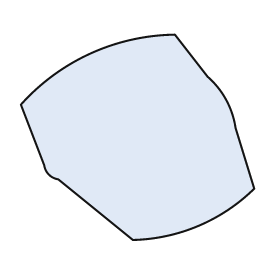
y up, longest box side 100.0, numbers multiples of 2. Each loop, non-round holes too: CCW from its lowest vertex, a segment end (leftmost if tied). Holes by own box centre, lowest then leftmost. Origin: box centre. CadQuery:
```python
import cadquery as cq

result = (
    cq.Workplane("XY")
    .moveTo(-2.0, -44.0)
    .threePointArc((26.0, -38.0), (50.0, -22.0))
    .lineTo(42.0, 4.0)
    .threePointArc((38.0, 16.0), (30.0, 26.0))
    .lineTo(16.0, 44.0)
    .threePointArc((-20.0, 36.0), (-50.0, 14.0))
    .lineTo(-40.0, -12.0)
    .threePointArc((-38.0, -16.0), (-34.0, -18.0))
    .close()
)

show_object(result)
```